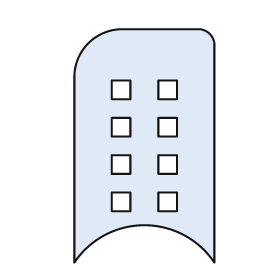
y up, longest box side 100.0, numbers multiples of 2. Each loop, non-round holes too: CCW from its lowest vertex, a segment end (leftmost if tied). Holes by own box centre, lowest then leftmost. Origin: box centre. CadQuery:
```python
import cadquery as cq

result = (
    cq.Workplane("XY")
    .moveTo(-30.0, -50.0)
    .threePointArc((0.0, -34.0), (30.0, -50.0))
    .lineTo(30.0, 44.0)
    .threePointArc((28.0, 48.0), (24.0, 50.0))
    .lineTo(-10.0, 50.0)
    .threePointArc((-24.0, 44.0), (-30.0, 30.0))
    .close()
    .moveTo(-14.0, -28.0)
    .lineTo(-6.0, -28.0)
    .lineTo(-6.0, -20.0)
    .lineTo(-14.0, -20.0)
    .close()
    .moveTo(6.0, -28.0)
    .lineTo(14.0, -28.0)
    .lineTo(14.0, -20.0)
    .lineTo(6.0, -20.0)
    .close()
    .moveTo(-14.0, -12.0)
    .lineTo(-6.0, -12.0)
    .lineTo(-6.0, -4.0)
    .lineTo(-14.0, -4.0)
    .close()
    .moveTo(6.0, -12.0)
    .lineTo(14.0, -12.0)
    .lineTo(14.0, -4.0)
    .lineTo(6.0, -4.0)
    .close()
    .moveTo(-14.0, 4.0)
    .lineTo(-6.0, 4.0)
    .lineTo(-6.0, 12.0)
    .lineTo(-14.0, 12.0)
    .close()
    .moveTo(6.0, 4.0)
    .lineTo(14.0, 4.0)
    .lineTo(14.0, 12.0)
    .lineTo(6.0, 12.0)
    .close()
    .moveTo(-14.0, 20.0)
    .lineTo(-6.0, 20.0)
    .lineTo(-6.0, 28.0)
    .lineTo(-14.0, 28.0)
    .close()
    .moveTo(6.0, 20.0)
    .lineTo(14.0, 20.0)
    .lineTo(14.0, 28.0)
    .lineTo(6.0, 28.0)
    .close()
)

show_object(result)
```